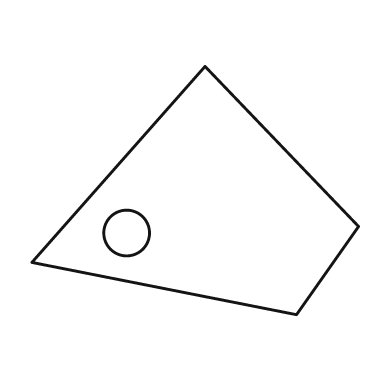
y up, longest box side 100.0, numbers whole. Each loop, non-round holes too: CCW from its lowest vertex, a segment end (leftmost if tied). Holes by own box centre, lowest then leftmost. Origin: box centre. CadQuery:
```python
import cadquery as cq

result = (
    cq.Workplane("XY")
    .moveTo(31.0, -38.0)
    .lineTo(50.0, -11.0)
    .lineTo(3.0, 38.0)
    .lineTo(-50.0, -22.0)
    .close()
    .moveTo(-21.0, -13.0)
    .circle(7.0)
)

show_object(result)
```